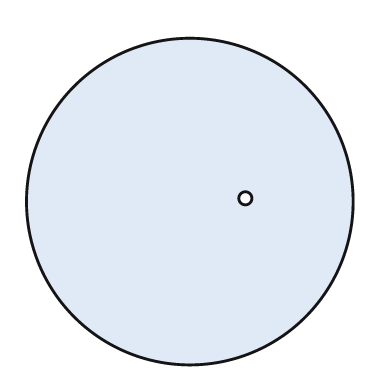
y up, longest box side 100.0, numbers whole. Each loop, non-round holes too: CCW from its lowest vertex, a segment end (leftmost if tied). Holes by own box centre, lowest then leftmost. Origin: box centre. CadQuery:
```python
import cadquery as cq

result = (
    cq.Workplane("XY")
    .moveTo(0.0, 0.0)
    .circle(50.0)
    .moveTo(17.0, 1.0)
    .circle(2.0)
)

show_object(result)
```